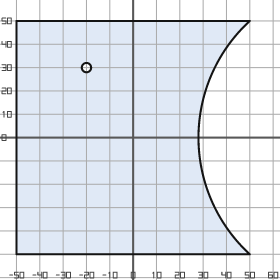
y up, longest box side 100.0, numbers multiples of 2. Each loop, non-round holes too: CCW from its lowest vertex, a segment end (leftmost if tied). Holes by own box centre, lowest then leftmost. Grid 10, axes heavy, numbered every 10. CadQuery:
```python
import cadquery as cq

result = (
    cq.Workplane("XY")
    .moveTo(-50.0, -50.0)
    .lineTo(50.0, -50.0)
    .threePointArc((28.0, 0.0), (50.0, 50.0))
    .lineTo(-50.0, 50.0)
    .close()
    .moveTo(-20.0, 30.0)
    .circle(2.0)
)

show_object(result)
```